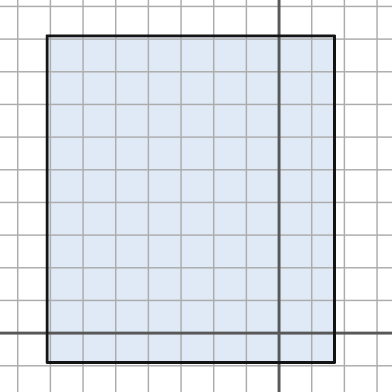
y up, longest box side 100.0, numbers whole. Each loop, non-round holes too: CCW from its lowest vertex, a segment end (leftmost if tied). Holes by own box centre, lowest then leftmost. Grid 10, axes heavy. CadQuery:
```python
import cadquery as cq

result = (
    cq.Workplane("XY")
    .moveTo(-71.0, -9.0)
    .lineTo(17.0, -9.0)
    .lineTo(17.0, 91.0)
    .lineTo(-71.0, 91.0)
    .close()
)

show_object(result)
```